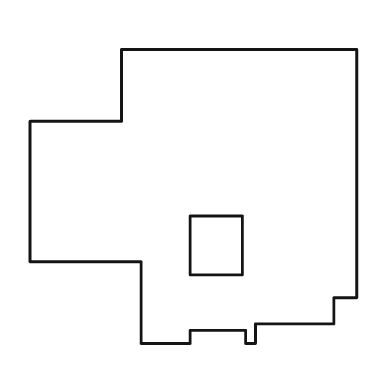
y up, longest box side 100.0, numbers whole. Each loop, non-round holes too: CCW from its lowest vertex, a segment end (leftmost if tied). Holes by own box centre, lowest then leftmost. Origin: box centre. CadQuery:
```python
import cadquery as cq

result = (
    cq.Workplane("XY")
    .moveTo(-16.0, -45.0)
    .lineTo(-1.0, -45.0)
    .lineTo(-1.0, -41.0)
    .lineTo(16.0, -41.0)
    .lineTo(16.0, -45.0)
    .lineTo(19.0, -45.0)
    .lineTo(19.0, -39.0)
    .lineTo(43.0, -39.0)
    .lineTo(43.0, -31.0)
    .lineTo(50.0, -31.0)
    .lineTo(50.0, 45.0)
    .lineTo(-22.0, 45.0)
    .lineTo(-22.0, 23.0)
    .lineTo(-50.0, 23.0)
    .lineTo(-50.0, -20.0)
    .lineTo(-16.0, -20.0)
    .close()
    .moveTo(-1.0, -24.0)
    .lineTo(15.0, -24.0)
    .lineTo(15.0, -6.0)
    .lineTo(-1.0, -6.0)
    .close()
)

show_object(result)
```